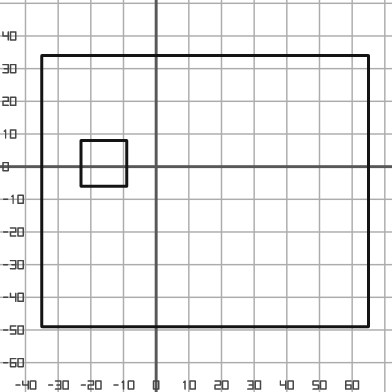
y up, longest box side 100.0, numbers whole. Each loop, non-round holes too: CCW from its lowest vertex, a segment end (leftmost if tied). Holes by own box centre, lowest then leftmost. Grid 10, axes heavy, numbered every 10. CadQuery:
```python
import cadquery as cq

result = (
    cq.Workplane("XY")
    .moveTo(-35.0, -49.0)
    .lineTo(65.0, -49.0)
    .lineTo(65.0, 34.0)
    .lineTo(-35.0, 34.0)
    .close()
    .moveTo(-23.0, -6.0)
    .lineTo(-9.0, -6.0)
    .lineTo(-9.0, 8.0)
    .lineTo(-23.0, 8.0)
    .close()
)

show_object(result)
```